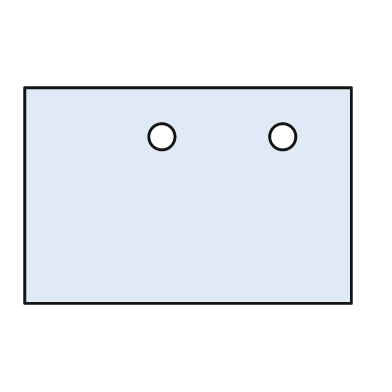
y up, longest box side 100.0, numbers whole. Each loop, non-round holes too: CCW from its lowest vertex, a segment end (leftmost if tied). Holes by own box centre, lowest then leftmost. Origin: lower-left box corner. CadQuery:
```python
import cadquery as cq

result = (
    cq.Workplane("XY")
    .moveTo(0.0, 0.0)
    .lineTo(100.0, 0.0)
    .lineTo(100.0, 66.0)
    .lineTo(0.0, 66.0)
    .close()
    .moveTo(42.0, 51.0)
    .circle(4.0)
    .moveTo(79.0, 51.0)
    .circle(4.0)
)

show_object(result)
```